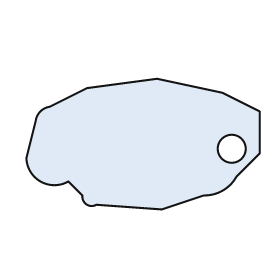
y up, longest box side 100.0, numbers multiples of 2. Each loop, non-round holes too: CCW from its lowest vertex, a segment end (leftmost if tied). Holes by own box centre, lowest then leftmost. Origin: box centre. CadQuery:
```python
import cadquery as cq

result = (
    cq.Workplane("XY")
    .moveTo(8.0, -28.0)
    .lineTo(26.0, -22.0)
    .threePointArc((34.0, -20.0), (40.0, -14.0))
    .lineTo(50.0, -4.0)
    .lineTo(50.0, 14.0)
    .lineTo(34.0, 22.0)
    .lineTo(6.0, 28.0)
    .lineTo(-24.0, 24.0)
    .lineTo(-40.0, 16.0)
    .threePointArc((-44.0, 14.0), (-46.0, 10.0))
    .lineTo(-50.0, -6.0)
    .threePointArc((-44.0, -16.0), (-32.0, -16.0))
    .lineTo(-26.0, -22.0)
    .threePointArc((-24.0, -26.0), (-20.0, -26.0))
    .close()
    .moveTo(38.0, -2.0)
    .circle(6.0)
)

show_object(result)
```